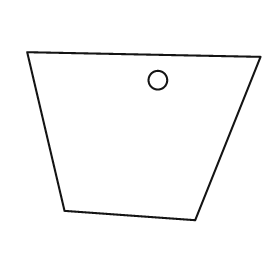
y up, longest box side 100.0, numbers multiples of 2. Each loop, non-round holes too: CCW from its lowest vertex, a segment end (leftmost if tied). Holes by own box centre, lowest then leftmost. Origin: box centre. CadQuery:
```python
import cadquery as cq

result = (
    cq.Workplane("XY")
    .moveTo(22.0, -36.0)
    .lineTo(50.0, 34.0)
    .lineTo(-50.0, 36.0)
    .lineTo(-34.0, -32.0)
    .close()
    .moveTo(6.0, 24.0)
    .circle(4.0)
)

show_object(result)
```